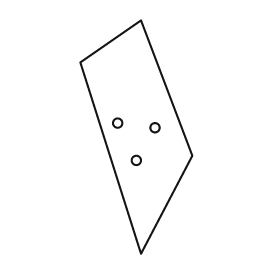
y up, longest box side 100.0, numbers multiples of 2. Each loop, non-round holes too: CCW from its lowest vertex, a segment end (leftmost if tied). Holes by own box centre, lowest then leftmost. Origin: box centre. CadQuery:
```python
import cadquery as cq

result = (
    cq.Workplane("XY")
    .moveTo(2.0, -50.0)
    .lineTo(24.0, -8.0)
    .lineTo(2.0, 50.0)
    .lineTo(-24.0, 32.0)
    .close()
    .moveTo(0.0, -10.0)
    .circle(2.0)
    .moveTo(8.0, 4.0)
    .circle(2.0)
    .moveTo(-8.0, 6.0)
    .circle(2.0)
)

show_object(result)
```